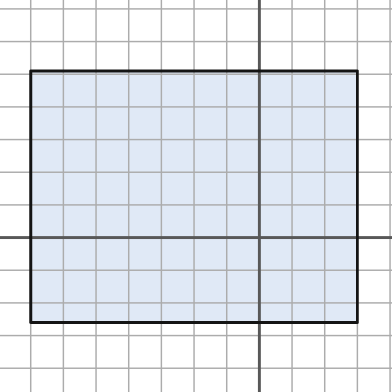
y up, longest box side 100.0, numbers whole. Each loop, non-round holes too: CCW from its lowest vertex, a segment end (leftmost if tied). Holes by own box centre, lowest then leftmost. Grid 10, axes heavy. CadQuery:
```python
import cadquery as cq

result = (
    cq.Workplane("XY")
    .moveTo(-70.0, -26.0)
    .lineTo(30.0, -26.0)
    .lineTo(30.0, 51.0)
    .lineTo(-70.0, 51.0)
    .close()
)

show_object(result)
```